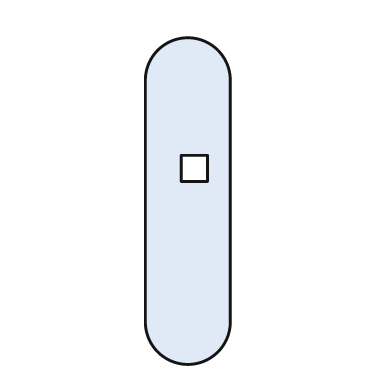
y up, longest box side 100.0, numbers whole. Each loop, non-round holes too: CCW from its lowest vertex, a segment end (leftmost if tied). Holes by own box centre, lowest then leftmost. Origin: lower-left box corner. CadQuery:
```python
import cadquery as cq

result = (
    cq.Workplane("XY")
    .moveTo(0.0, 13.0)
    .threePointArc((13.0, 0.0), (26.0, 13.0))
    .lineTo(26.0, 87.0)
    .threePointArc((13.0, 100.0), (0.0, 87.0))
    .close()
    .moveTo(11.0, 56.0)
    .lineTo(19.0, 56.0)
    .lineTo(19.0, 64.0)
    .lineTo(11.0, 64.0)
    .close()
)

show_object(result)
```